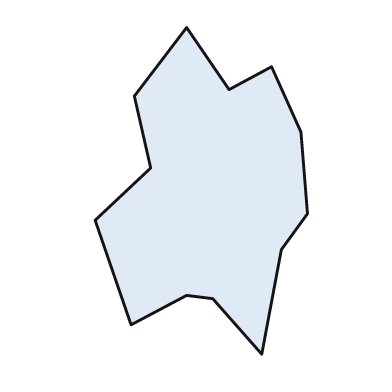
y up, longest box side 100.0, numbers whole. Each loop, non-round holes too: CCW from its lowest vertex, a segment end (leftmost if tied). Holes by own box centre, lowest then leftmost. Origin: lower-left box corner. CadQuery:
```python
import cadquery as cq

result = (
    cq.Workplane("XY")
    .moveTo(51.0, 0.0)
    .lineTo(57.0, 32.0)
    .lineTo(65.0, 43.0)
    .lineTo(63.0, 68.0)
    .lineTo(54.0, 88.0)
    .lineTo(41.0, 81.0)
    .lineTo(28.0, 100.0)
    .lineTo(12.0, 79.0)
    .lineTo(17.0, 57.0)
    .lineTo(0.0, 41.0)
    .lineTo(11.0, 9.0)
    .lineTo(28.0, 18.0)
    .lineTo(36.0, 17.0)
    .close()
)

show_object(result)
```